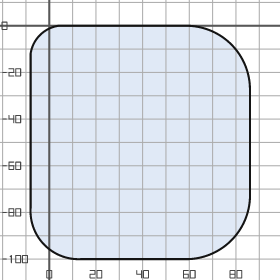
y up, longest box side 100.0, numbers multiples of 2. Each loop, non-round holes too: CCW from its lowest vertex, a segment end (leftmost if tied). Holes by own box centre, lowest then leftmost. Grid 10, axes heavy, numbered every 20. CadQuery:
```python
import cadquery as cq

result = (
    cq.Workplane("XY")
    .moveTo(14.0, -100.0)
    .lineTo(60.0, -100.0)
    .threePointArc((78.0, -92.0), (86.0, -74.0))
    .lineTo(86.0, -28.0)
    .threePointArc((78.0, -8.0), (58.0, 0.0))
    .lineTo(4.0, 0.0)
    .threePointArc((-4.0, -4.0), (-8.0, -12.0))
    .lineTo(-8.0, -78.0)
    .threePointArc((-2.0, -94.0), (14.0, -100.0))
    .close()
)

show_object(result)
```